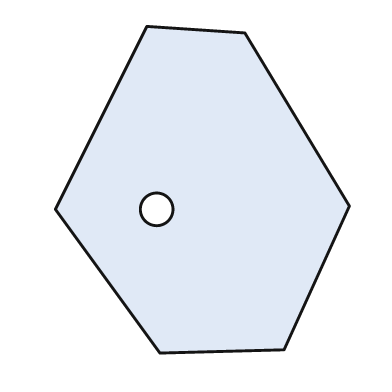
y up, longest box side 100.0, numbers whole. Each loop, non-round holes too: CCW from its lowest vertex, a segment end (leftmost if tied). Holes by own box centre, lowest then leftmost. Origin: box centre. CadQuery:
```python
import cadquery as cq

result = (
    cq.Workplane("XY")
    .moveTo(-13.0, -50.0)
    .lineTo(25.0, -49.0)
    .lineTo(45.0, -5.0)
    .lineTo(13.0, 48.0)
    .lineTo(-17.0, 50.0)
    .lineTo(-45.0, -6.0)
    .close()
    .moveTo(-14.0, -6.0)
    .circle(5.0)
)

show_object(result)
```